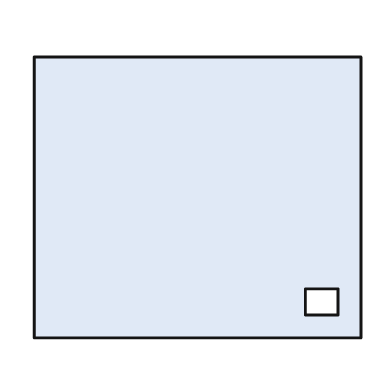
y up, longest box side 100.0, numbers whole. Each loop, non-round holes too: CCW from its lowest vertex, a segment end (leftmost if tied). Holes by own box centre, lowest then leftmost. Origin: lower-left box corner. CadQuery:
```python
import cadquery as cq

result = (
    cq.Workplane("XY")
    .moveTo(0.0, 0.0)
    .lineTo(100.0, 0.0)
    .lineTo(100.0, 86.0)
    .lineTo(0.0, 86.0)
    .close()
    .moveTo(83.0, 7.0)
    .lineTo(93.0, 7.0)
    .lineTo(93.0, 15.0)
    .lineTo(83.0, 15.0)
    .close()
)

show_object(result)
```